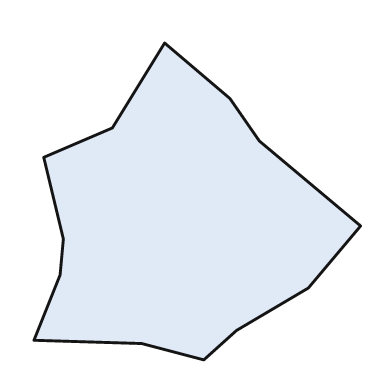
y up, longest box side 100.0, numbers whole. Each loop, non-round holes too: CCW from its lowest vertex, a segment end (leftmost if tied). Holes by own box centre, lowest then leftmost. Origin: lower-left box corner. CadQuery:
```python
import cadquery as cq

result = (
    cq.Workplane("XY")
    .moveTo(52.0, 0.0)
    .lineTo(62.0, 9.0)
    .lineTo(84.0, 22.0)
    .lineTo(100.0, 41.0)
    .lineTo(69.0, 67.0)
    .lineTo(60.0, 80.0)
    .lineTo(40.0, 97.0)
    .lineTo(24.0, 71.0)
    .lineTo(3.0, 62.0)
    .lineTo(9.0, 37.0)
    .lineTo(8.0, 26.0)
    .lineTo(0.0, 6.0)
    .lineTo(33.0, 5.0)
    .close()
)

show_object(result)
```